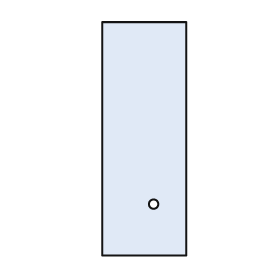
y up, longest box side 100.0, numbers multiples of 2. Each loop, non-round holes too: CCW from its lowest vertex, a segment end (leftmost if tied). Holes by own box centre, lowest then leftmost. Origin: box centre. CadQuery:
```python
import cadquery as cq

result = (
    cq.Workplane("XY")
    .moveTo(-18.0, -50.0)
    .lineTo(18.0, -50.0)
    .lineTo(18.0, 50.0)
    .lineTo(-18.0, 50.0)
    .close()
    .moveTo(4.0, -28.0)
    .circle(2.0)
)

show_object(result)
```